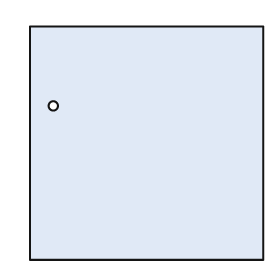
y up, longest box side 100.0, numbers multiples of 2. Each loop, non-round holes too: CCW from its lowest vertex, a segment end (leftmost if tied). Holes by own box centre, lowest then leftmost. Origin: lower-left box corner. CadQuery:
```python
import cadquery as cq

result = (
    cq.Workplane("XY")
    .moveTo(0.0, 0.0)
    .lineTo(100.0, 0.0)
    .lineTo(100.0, 100.0)
    .lineTo(0.0, 100.0)
    .close()
    .moveTo(10.0, 66.0)
    .circle(2.0)
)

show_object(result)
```